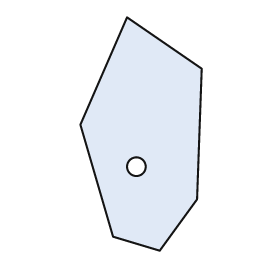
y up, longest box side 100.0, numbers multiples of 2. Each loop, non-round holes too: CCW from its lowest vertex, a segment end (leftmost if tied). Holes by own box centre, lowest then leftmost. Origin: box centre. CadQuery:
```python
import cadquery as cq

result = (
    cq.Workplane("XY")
    .moveTo(8.0, -50.0)
    .lineTo(24.0, -28.0)
    .lineTo(26.0, 28.0)
    .lineTo(-6.0, 50.0)
    .lineTo(-26.0, 4.0)
    .lineTo(-12.0, -44.0)
    .close()
    .moveTo(-2.0, -14.0)
    .circle(4.0)
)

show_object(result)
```